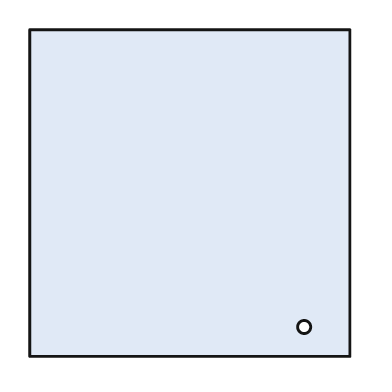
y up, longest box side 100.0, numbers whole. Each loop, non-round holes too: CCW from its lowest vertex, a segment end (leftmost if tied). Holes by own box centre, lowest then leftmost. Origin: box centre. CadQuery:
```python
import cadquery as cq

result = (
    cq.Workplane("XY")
    .moveTo(-49.0, -50.0)
    .lineTo(49.0, -50.0)
    .lineTo(49.0, 50.0)
    .lineTo(-49.0, 50.0)
    .close()
    .moveTo(35.0, -41.0)
    .circle(2.0)
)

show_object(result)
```